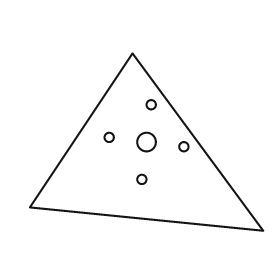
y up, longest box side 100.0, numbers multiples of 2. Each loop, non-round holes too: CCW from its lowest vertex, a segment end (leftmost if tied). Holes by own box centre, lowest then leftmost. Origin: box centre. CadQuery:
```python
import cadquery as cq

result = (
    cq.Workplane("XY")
    .moveTo(50.0, -38.0)
    .lineTo(-6.0, 38.0)
    .lineTo(-50.0, -28.0)
    .close()
    .moveTo(-2.0, -16.0)
    .circle(2.0)
    .moveTo(16.0, -2.0)
    .circle(2.0)
    .moveTo(0.0, 0.0)
    .circle(4.0)
    .moveTo(-16.0, 2.0)
    .circle(2.0)
    .moveTo(2.0, 16.0)
    .circle(2.0)
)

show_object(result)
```